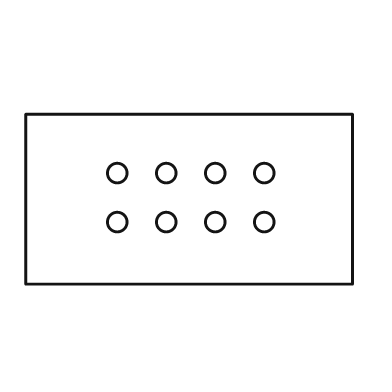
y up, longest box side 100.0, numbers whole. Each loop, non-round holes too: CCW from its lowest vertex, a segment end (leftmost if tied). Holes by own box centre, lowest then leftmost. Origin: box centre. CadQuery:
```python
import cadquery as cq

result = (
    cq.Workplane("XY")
    .moveTo(-50.0, -26.0)
    .lineTo(50.0, -26.0)
    .lineTo(50.0, 26.0)
    .lineTo(-50.0, 26.0)
    .close()
    .moveTo(-22.0, -7.0)
    .circle(3.0)
    .moveTo(-7.0, -7.0)
    .circle(3.0)
    .moveTo(8.0, -7.0)
    .circle(3.0)
    .moveTo(23.0, -7.0)
    .circle(3.0)
    .moveTo(-22.0, 8.0)
    .circle(3.0)
    .moveTo(-7.0, 8.0)
    .circle(3.0)
    .moveTo(8.0, 8.0)
    .circle(3.0)
    .moveTo(23.0, 8.0)
    .circle(3.0)
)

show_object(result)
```